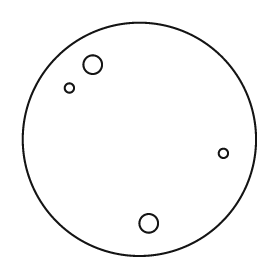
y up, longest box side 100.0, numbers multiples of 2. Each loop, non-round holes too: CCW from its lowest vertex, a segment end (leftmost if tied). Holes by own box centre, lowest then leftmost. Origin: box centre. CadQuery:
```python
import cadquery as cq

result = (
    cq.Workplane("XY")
    .moveTo(0.0, 0.0)
    .circle(50.0)
    .moveTo(4.0, -36.0)
    .circle(4.0)
    .moveTo(36.0, -6.0)
    .circle(2.0)
    .moveTo(-30.0, 22.0)
    .circle(2.0)
    .moveTo(-20.0, 32.0)
    .circle(4.0)
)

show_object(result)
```